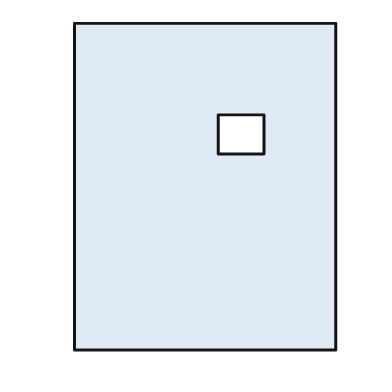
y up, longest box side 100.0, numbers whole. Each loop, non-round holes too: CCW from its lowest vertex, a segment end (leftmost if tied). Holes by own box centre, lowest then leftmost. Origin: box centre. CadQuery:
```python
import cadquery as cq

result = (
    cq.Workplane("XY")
    .moveTo(-40.0, -50.0)
    .lineTo(40.0, -50.0)
    .lineTo(40.0, 50.0)
    .lineTo(-40.0, 50.0)
    .close()
    .moveTo(4.0, 10.0)
    .lineTo(18.0, 10.0)
    .lineTo(18.0, 22.0)
    .lineTo(4.0, 22.0)
    .close()
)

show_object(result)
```